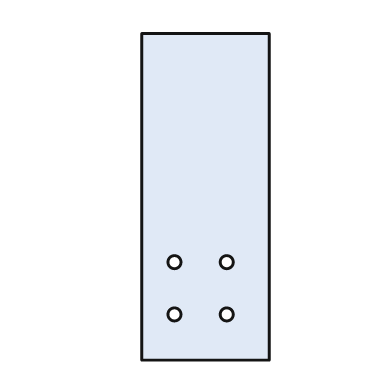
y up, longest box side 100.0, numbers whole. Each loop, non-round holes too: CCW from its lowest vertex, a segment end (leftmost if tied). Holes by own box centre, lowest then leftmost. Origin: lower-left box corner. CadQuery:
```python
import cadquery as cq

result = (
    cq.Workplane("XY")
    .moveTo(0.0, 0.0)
    .lineTo(39.0, 0.0)
    .lineTo(39.0, 100.0)
    .lineTo(0.0, 100.0)
    .close()
    .moveTo(10.0, 14.0)
    .circle(2.0)
    .moveTo(26.0, 14.0)
    .circle(2.0)
    .moveTo(10.0, 30.0)
    .circle(2.0)
    .moveTo(26.0, 30.0)
    .circle(2.0)
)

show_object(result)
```